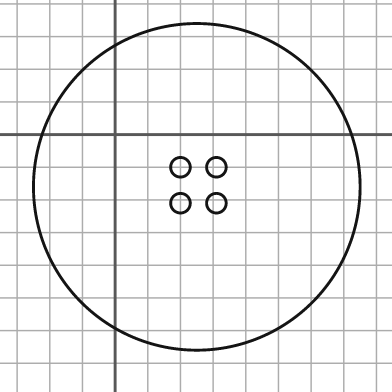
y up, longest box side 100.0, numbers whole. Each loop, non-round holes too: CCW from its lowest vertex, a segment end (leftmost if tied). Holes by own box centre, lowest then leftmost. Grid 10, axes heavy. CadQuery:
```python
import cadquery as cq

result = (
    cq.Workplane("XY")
    .moveTo(25.0, -16.0)
    .circle(50.0)
    .moveTo(20.0, -21.0)
    .circle(3.0)
    .moveTo(31.0, -21.0)
    .circle(3.0)
    .moveTo(20.0, -10.0)
    .circle(3.0)
    .moveTo(31.0, -10.0)
    .circle(3.0)
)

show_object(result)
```